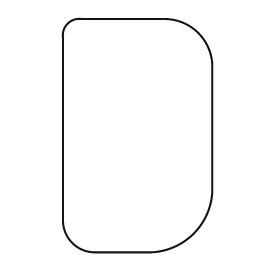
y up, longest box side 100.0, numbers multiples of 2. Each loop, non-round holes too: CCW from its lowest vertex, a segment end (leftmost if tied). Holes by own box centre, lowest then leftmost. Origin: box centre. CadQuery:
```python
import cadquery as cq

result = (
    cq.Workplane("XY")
    .moveTo(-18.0, -50.0)
    .lineTo(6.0, -50.0)
    .threePointArc((24.0, -42.0), (32.0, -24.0))
    .lineTo(32.0, 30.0)
    .threePointArc((26.0, 44.0), (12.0, 50.0))
    .lineTo(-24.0, 50.0)
    .threePointArc((-30.0, 48.0), (-32.0, 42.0))
    .lineTo(-32.0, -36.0)
    .threePointArc((-28.0, -46.0), (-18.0, -50.0))
    .close()
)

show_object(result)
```